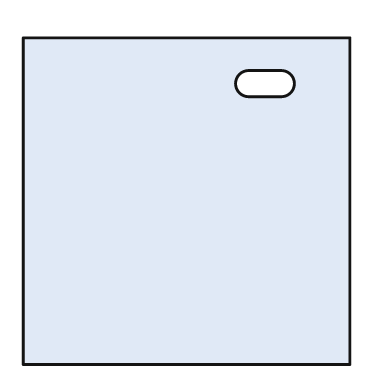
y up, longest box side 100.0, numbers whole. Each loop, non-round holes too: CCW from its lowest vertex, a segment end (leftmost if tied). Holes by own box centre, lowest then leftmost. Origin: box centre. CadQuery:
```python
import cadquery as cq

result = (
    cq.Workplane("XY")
    .moveTo(-50.0, -50.0)
    .lineTo(50.0, -50.0)
    .lineTo(50.0, 50.0)
    .lineTo(-50.0, 50.0)
    .close()
    .moveTo(19.0, 32.0)
    .lineTo(29.0, 32.0)
    .threePointArc((33.0, 36.0), (29.0, 40.0))
    .lineTo(19.0, 40.0)
    .threePointArc((15.0, 36.0), (19.0, 32.0))
    .close()
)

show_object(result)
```